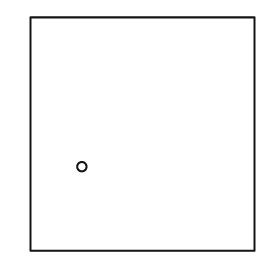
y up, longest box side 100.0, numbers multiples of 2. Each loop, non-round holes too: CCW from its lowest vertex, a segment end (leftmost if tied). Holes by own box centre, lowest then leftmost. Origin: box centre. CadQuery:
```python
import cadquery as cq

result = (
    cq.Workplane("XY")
    .moveTo(-48.0, -50.0)
    .lineTo(48.0, -50.0)
    .lineTo(48.0, 50.0)
    .lineTo(-48.0, 50.0)
    .close()
    .moveTo(-26.0, -14.0)
    .circle(2.0)
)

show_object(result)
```